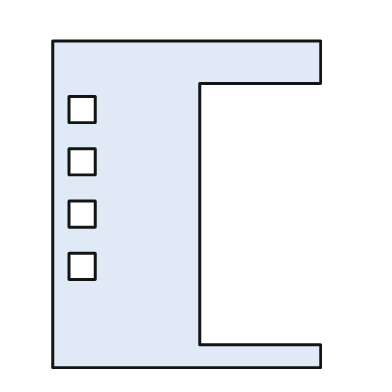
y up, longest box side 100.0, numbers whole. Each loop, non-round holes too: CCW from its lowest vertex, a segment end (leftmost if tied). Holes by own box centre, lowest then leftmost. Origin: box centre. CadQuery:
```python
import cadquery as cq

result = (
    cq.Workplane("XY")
    .moveTo(-41.0, -50.0)
    .lineTo(41.0, -50.0)
    .lineTo(41.0, -43.0)
    .lineTo(4.0, -43.0)
    .lineTo(4.0, 37.0)
    .lineTo(41.0, 37.0)
    .lineTo(41.0, 50.0)
    .lineTo(-41.0, 50.0)
    .close()
    .moveTo(-36.0, -23.0)
    .lineTo(-28.0, -23.0)
    .lineTo(-28.0, -15.0)
    .lineTo(-36.0, -15.0)
    .close()
    .moveTo(-36.0, -7.0)
    .lineTo(-28.0, -7.0)
    .lineTo(-28.0, 1.0)
    .lineTo(-36.0, 1.0)
    .close()
    .moveTo(-36.0, 9.0)
    .lineTo(-28.0, 9.0)
    .lineTo(-28.0, 17.0)
    .lineTo(-36.0, 17.0)
    .close()
    .moveTo(-36.0, 25.0)
    .lineTo(-28.0, 25.0)
    .lineTo(-28.0, 33.0)
    .lineTo(-36.0, 33.0)
    .close()
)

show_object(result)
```